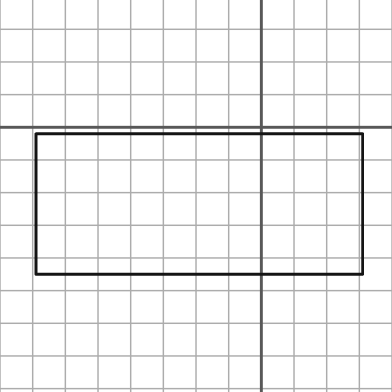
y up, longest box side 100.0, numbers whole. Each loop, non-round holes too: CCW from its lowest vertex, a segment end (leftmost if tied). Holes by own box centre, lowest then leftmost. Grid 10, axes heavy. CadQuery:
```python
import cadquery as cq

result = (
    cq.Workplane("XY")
    .moveTo(-69.0, -45.0)
    .lineTo(31.0, -45.0)
    .lineTo(31.0, -2.0)
    .lineTo(-69.0, -2.0)
    .close()
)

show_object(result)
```